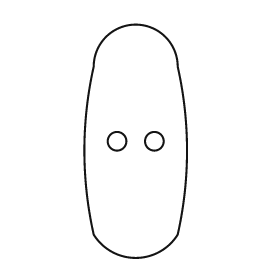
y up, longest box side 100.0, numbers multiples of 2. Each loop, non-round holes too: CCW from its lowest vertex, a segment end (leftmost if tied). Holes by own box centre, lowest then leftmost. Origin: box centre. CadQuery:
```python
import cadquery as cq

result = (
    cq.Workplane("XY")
    .moveTo(-18.0, -40.0)
    .threePointArc((0.0, -50.0), (18.0, -40.0))
    .threePointArc((22.0, -4.0), (18.0, 32.0))
    .threePointArc((0.0, 50.0), (-18.0, 32.0))
    .threePointArc((-22.0, -4.0), (-18.0, -40.0))
    .close()
    .moveTo(-8.0, 0.0)
    .circle(4.0)
    .moveTo(8.0, 0.0)
    .circle(4.0)
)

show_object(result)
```